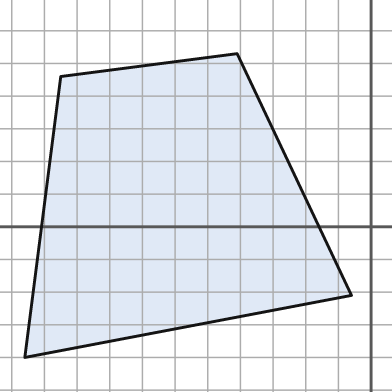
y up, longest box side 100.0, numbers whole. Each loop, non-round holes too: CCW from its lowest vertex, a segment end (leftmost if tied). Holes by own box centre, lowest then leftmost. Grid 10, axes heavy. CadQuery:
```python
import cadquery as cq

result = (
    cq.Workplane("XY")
    .moveTo(-106.0, -40.0)
    .lineTo(-6.0, -21.0)
    .lineTo(-41.0, 53.0)
    .lineTo(-95.0, 46.0)
    .close()
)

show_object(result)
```